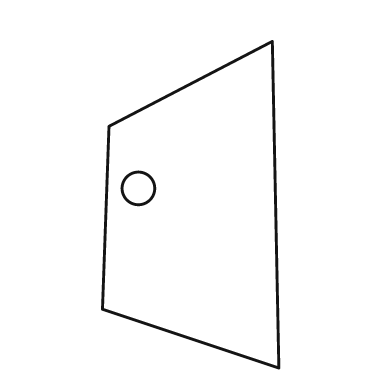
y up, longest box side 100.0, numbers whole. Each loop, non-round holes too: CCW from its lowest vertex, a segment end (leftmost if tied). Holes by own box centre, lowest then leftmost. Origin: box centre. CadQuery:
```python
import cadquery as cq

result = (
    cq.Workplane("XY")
    .moveTo(27.0, -50.0)
    .lineTo(25.0, 50.0)
    .lineTo(-25.0, 24.0)
    .lineTo(-27.0, -32.0)
    .close()
    .moveTo(-16.0, 5.0)
    .circle(5.0)
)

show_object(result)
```